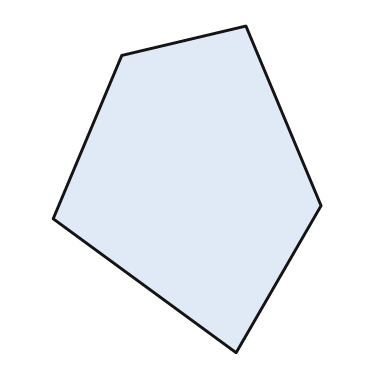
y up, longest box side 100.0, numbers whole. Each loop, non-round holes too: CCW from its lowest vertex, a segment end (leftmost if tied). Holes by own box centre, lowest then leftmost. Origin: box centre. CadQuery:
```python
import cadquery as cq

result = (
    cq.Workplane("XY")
    .moveTo(15.0, -50.0)
    .lineTo(41.0, -5.0)
    .lineTo(18.0, 50.0)
    .lineTo(-20.0, 41.0)
    .lineTo(-41.0, -9.0)
    .close()
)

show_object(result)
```